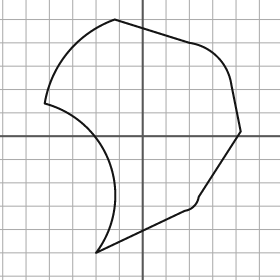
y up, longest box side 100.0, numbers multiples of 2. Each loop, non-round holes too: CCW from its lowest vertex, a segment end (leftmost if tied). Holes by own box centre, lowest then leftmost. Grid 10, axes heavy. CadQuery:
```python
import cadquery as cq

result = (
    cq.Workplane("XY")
    .moveTo(-20.0, -50.0)
    .lineTo(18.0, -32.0)
    .threePointArc((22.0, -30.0), (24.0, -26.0))
    .lineTo(42.0, 2.0)
    .lineTo(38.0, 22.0)
    .threePointArc((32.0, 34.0), (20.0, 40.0))
    .lineTo(-12.0, 50.0)
    .threePointArc((-32.0, 36.0), (-42.0, 14.0))
    .threePointArc((-14.0, -12.0), (-20.0, -50.0))
    .close()
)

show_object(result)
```